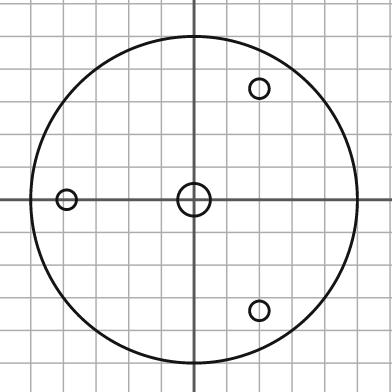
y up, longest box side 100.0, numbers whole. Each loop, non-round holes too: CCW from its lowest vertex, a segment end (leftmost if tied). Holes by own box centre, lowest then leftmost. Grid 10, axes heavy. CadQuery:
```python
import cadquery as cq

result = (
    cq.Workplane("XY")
    .moveTo(0.0, 0.0)
    .circle(50.0)
    .moveTo(20.0, -34.0)
    .circle(3.0)
    .moveTo(-39.0, 0.0)
    .circle(3.0)
    .moveTo(0.0, 0.0)
    .circle(5.0)
    .moveTo(20.0, 34.0)
    .circle(3.0)
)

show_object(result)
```